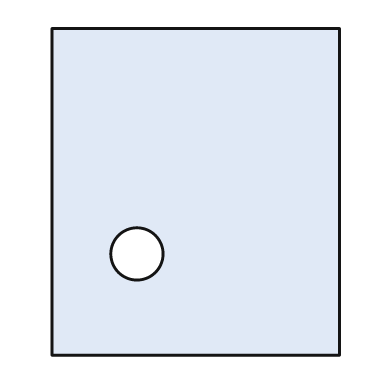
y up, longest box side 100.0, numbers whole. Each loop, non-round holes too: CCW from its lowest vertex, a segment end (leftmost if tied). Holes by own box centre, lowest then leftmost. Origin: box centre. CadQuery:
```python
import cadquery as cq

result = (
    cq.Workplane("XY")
    .moveTo(-44.0, -50.0)
    .lineTo(44.0, -50.0)
    .lineTo(44.0, 50.0)
    .lineTo(-44.0, 50.0)
    .close()
    .moveTo(-18.0, -19.0)
    .circle(8.0)
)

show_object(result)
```